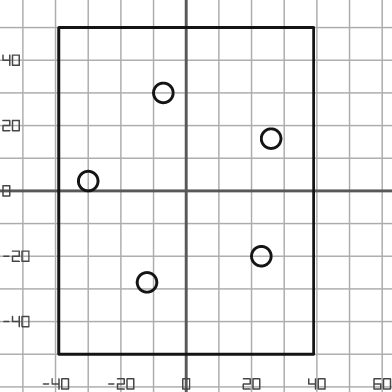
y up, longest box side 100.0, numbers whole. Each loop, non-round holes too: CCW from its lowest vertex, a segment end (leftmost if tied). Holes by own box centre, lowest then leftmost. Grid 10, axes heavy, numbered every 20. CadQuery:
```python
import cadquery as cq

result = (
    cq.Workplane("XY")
    .moveTo(-39.0, -50.0)
    .lineTo(39.0, -50.0)
    .lineTo(39.0, 50.0)
    .lineTo(-39.0, 50.0)
    .close()
    .moveTo(-12.0, -28.0)
    .circle(3.0)
    .moveTo(23.0, -20.0)
    .circle(3.0)
    .moveTo(-30.0, 3.0)
    .circle(3.0)
    .moveTo(26.0, 16.0)
    .circle(3.0)
    .moveTo(-7.0, 30.0)
    .circle(3.0)
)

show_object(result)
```